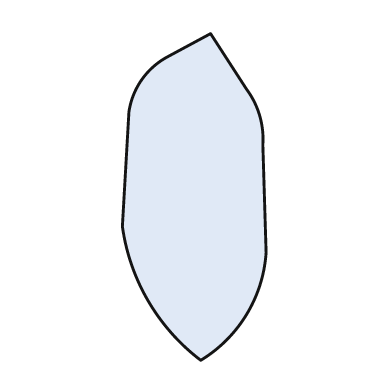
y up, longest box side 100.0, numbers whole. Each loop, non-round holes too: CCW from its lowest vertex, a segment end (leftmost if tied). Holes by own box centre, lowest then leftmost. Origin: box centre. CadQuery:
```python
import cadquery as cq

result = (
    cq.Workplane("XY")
    .moveTo(2.0, -50.0)
    .threePointArc((16.0, -36.0), (22.0, -17.0))
    .lineTo(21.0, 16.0)
    .threePointArc((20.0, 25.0), (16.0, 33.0))
    .lineTo(5.0, 50.0)
    .lineTo(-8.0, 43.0)
    .threePointArc((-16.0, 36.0), (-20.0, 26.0))
    .lineTo(-22.0, -9.0)
    .threePointArc((-14.0, -32.0), (2.0, -50.0))
    .close()
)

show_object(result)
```